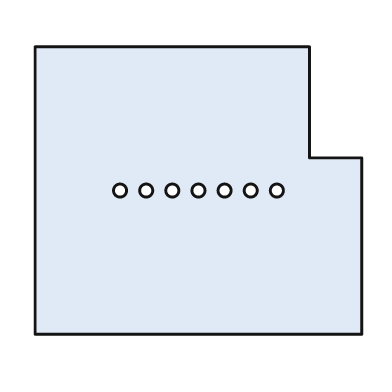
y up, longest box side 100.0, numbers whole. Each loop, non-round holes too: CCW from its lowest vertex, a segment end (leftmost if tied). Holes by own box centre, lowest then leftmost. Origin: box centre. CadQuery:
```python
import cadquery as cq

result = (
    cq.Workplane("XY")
    .moveTo(-50.0, -44.0)
    .lineTo(50.0, -44.0)
    .lineTo(50.0, 10.0)
    .lineTo(34.0, 10.0)
    .lineTo(34.0, 44.0)
    .lineTo(-50.0, 44.0)
    .close()
    .moveTo(-24.0, 0.0)
    .circle(2.0)
    .moveTo(-16.0, 0.0)
    .circle(2.0)
    .moveTo(-8.0, 0.0)
    .circle(2.0)
    .moveTo(0.0, 0.0)
    .circle(2.0)
    .moveTo(8.0, 0.0)
    .circle(2.0)
    .moveTo(16.0, 0.0)
    .circle(2.0)
    .moveTo(24.0, 0.0)
    .circle(2.0)
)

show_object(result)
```